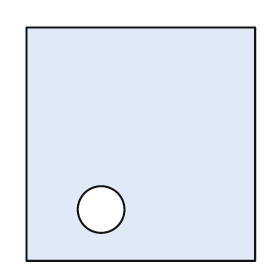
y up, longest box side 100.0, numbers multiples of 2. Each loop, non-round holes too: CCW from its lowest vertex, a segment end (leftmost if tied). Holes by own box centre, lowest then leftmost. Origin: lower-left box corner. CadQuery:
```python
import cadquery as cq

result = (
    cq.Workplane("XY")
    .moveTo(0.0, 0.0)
    .lineTo(98.0, 0.0)
    .lineTo(98.0, 100.0)
    .lineTo(0.0, 100.0)
    .close()
    .moveTo(32.0, 22.0)
    .circle(10.0)
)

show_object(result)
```